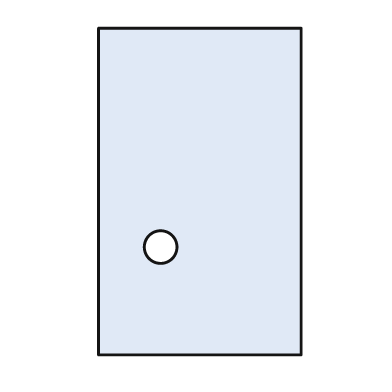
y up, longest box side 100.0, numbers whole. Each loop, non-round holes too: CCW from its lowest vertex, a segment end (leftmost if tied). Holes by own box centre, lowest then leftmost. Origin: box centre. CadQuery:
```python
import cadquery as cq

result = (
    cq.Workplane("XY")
    .moveTo(-31.0, -50.0)
    .lineTo(31.0, -50.0)
    .lineTo(31.0, 50.0)
    .lineTo(-31.0, 50.0)
    .close()
    .moveTo(-12.0, -17.0)
    .circle(5.0)
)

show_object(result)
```